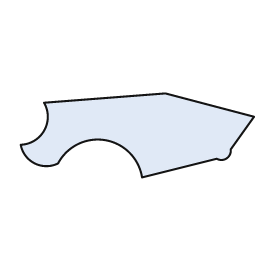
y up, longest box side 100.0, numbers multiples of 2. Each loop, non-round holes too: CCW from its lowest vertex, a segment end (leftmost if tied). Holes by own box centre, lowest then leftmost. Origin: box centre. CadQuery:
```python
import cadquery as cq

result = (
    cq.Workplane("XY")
    .moveTo(2.0, -18.0)
    .lineTo(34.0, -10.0)
    .threePointArc((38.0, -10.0), (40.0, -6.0))
    .lineTo(50.0, 8.0)
    .lineTo(12.0, 18.0)
    .lineTo(-40.0, 14.0)
    .threePointArc((-40.0, 2.0), (-50.0, -4.0))
    .threePointArc((-44.0, -12.0), (-34.0, -12.0))
    .threePointArc((-14.0, -2.0), (2.0, -18.0))
    .close()
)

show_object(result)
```